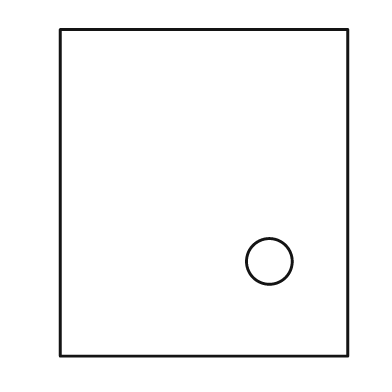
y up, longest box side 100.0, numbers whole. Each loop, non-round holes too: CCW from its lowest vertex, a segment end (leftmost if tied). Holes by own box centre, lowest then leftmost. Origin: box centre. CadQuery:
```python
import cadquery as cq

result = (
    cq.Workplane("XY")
    .moveTo(-44.0, -50.0)
    .lineTo(44.0, -50.0)
    .lineTo(44.0, 50.0)
    .lineTo(-44.0, 50.0)
    .close()
    .moveTo(20.0, -21.0)
    .circle(7.0)
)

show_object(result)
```